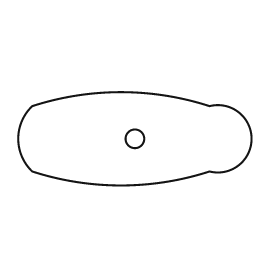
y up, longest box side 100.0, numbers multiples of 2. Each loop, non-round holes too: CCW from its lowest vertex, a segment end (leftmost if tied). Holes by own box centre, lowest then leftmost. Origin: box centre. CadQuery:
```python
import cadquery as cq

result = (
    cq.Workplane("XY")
    .moveTo(-44.0, -14.0)
    .threePointArc((-6.0, -20.0), (32.0, -14.0))
    .threePointArc((50.0, 0.0), (32.0, 14.0))
    .threePointArc((-6.0, 20.0), (-44.0, 14.0))
    .threePointArc((-50.0, 0.0), (-44.0, -14.0))
    .close()
    .moveTo(0.0, 0.0)
    .circle(4.0)
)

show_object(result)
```